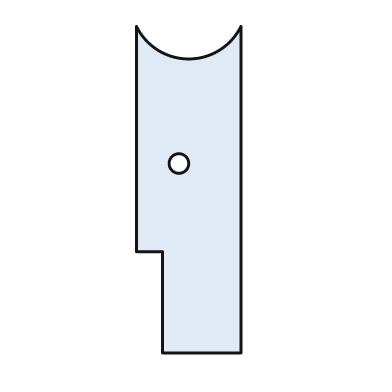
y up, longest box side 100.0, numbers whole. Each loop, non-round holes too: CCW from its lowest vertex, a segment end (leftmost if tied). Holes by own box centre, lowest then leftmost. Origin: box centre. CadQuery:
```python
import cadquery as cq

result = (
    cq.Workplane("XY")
    .moveTo(-8.0, -50.0)
    .lineTo(16.0, -50.0)
    .lineTo(16.0, 50.0)
    .threePointArc((0.0, 40.0), (-16.0, 50.0))
    .lineTo(-16.0, -19.0)
    .lineTo(-8.0, -19.0)
    .close()
    .moveTo(-3.0, 8.0)
    .circle(3.0)
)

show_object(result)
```